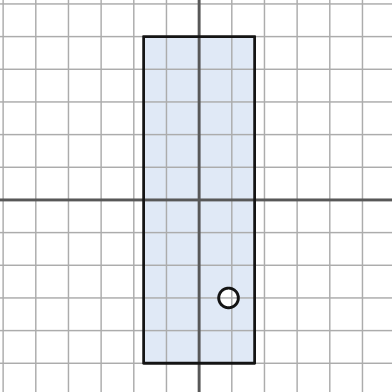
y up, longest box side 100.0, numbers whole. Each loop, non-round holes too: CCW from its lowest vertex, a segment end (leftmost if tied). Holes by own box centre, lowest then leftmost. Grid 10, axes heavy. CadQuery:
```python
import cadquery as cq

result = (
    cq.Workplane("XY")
    .moveTo(-17.0, -50.0)
    .lineTo(17.0, -50.0)
    .lineTo(17.0, 50.0)
    .lineTo(-17.0, 50.0)
    .close()
    .moveTo(9.0, -30.0)
    .circle(3.0)
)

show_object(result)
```